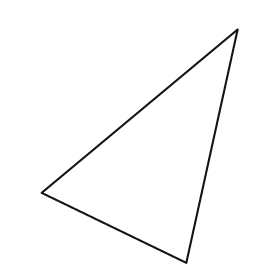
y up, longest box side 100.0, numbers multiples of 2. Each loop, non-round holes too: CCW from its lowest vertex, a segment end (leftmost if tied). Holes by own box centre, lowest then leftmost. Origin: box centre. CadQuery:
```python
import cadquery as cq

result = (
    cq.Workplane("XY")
    .moveTo(20.0, -50.0)
    .lineTo(42.0, 50.0)
    .lineTo(-42.0, -20.0)
    .close()
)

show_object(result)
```